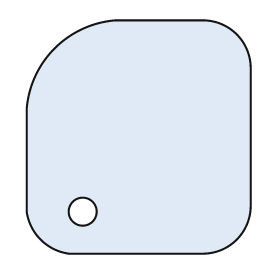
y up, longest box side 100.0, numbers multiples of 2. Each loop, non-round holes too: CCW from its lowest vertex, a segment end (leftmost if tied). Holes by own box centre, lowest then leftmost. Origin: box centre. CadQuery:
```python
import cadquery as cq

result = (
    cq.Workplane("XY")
    .moveTo(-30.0, -50.0)
    .lineTo(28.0, -50.0)
    .threePointArc((42.0, -44.0), (48.0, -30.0))
    .lineTo(48.0, 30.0)
    .threePointArc((42.0, 44.0), (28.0, 50.0))
    .lineTo(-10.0, 50.0)
    .threePointArc((-36.0, 38.0), (-48.0, 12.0))
    .lineTo(-48.0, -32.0)
    .threePointArc((-42.0, -44.0), (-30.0, -50.0))
    .close()
    .moveTo(-24.0, -32.0)
    .circle(6.0)
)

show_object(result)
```